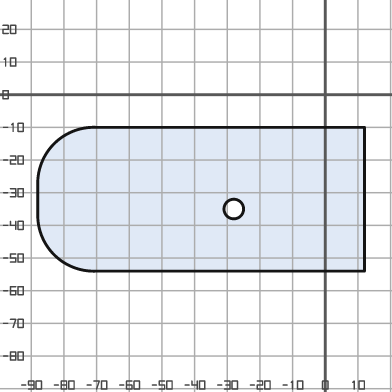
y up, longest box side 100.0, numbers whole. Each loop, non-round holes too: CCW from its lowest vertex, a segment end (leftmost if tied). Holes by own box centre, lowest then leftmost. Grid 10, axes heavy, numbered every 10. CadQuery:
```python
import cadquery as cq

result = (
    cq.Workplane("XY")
    .moveTo(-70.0, -54.0)
    .lineTo(12.0, -54.0)
    .lineTo(12.0, -10.0)
    .lineTo(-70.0, -10.0)
    .threePointArc((-83.0, -15.0), (-88.0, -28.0))
    .lineTo(-88.0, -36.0)
    .threePointArc((-83.0, -49.0), (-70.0, -54.0))
    .close()
    .moveTo(-28.0, -35.0)
    .circle(3.0)
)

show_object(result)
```